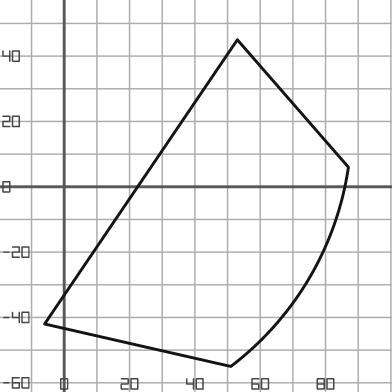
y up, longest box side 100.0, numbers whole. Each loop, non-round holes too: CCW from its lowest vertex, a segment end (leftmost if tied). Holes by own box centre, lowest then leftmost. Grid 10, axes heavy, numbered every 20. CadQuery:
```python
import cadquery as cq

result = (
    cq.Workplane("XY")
    .moveTo(51.0, -55.0)
    .threePointArc((75.0, -28.0), (87.0, 6.0))
    .lineTo(53.0, 45.0)
    .lineTo(-6.0, -42.0)
    .close()
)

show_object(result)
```